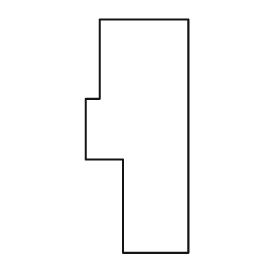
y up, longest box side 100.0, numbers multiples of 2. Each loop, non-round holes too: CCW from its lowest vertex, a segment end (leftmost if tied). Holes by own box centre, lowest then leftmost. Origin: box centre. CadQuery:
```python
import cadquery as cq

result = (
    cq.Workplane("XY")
    .moveTo(-6.0, -50.0)
    .lineTo(22.0, -50.0)
    .lineTo(22.0, 50.0)
    .lineTo(-16.0, 50.0)
    .lineTo(-16.0, 16.0)
    .lineTo(-22.0, 16.0)
    .lineTo(-22.0, -10.0)
    .lineTo(-6.0, -10.0)
    .close()
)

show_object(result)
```